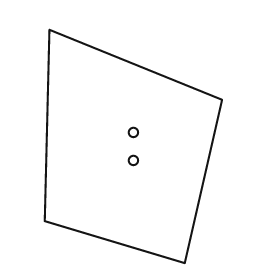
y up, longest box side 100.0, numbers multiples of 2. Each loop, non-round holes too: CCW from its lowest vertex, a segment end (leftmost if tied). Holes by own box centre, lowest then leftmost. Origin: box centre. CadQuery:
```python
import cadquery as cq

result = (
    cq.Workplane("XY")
    .moveTo(22.0, -50.0)
    .lineTo(38.0, 20.0)
    .lineTo(-36.0, 50.0)
    .lineTo(-38.0, -32.0)
    .close()
    .moveTo(0.0, -6.0)
    .circle(2.0)
    .moveTo(0.0, 6.0)
    .circle(2.0)
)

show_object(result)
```